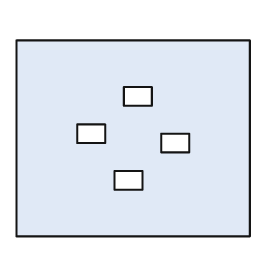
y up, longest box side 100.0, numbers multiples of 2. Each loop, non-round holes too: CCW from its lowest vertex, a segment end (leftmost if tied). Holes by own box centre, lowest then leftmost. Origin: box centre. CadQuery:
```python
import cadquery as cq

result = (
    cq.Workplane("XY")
    .moveTo(-50.0, -42.0)
    .lineTo(50.0, -42.0)
    .lineTo(50.0, 42.0)
    .lineTo(-50.0, 42.0)
    .close()
    .moveTo(-8.0, -22.0)
    .lineTo(4.0, -22.0)
    .lineTo(4.0, -14.0)
    .lineTo(-8.0, -14.0)
    .close()
    .moveTo(12.0, -6.0)
    .lineTo(24.0, -6.0)
    .lineTo(24.0, 2.0)
    .lineTo(12.0, 2.0)
    .close()
    .moveTo(-24.0, -2.0)
    .lineTo(-12.0, -2.0)
    .lineTo(-12.0, 6.0)
    .lineTo(-24.0, 6.0)
    .close()
    .moveTo(-4.0, 14.0)
    .lineTo(8.0, 14.0)
    .lineTo(8.0, 22.0)
    .lineTo(-4.0, 22.0)
    .close()
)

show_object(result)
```